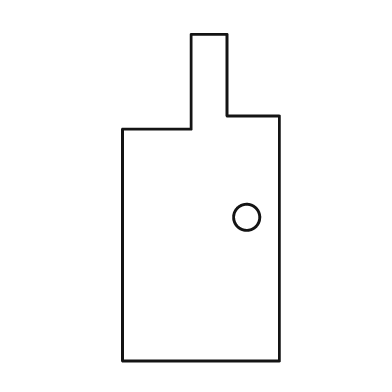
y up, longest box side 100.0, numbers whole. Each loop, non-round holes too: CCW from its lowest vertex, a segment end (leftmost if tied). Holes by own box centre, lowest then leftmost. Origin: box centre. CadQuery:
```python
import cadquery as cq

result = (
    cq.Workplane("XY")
    .moveTo(-24.0, -50.0)
    .lineTo(24.0, -50.0)
    .lineTo(24.0, 25.0)
    .lineTo(8.0, 25.0)
    .lineTo(8.0, 50.0)
    .lineTo(-3.0, 50.0)
    .lineTo(-3.0, 21.0)
    .lineTo(-24.0, 21.0)
    .close()
    .moveTo(14.0, -6.0)
    .circle(4.0)
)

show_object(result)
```